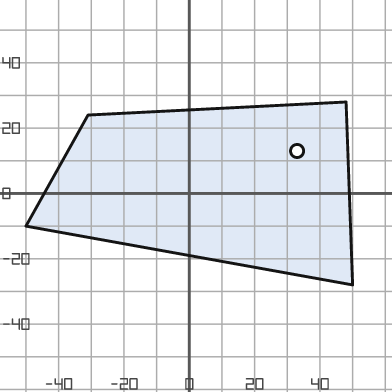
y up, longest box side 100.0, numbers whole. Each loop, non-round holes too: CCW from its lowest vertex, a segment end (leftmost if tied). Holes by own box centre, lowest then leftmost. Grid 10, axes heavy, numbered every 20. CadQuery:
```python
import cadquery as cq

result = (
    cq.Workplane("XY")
    .moveTo(50.0, -28.0)
    .lineTo(48.0, 28.0)
    .lineTo(-31.0, 24.0)
    .lineTo(-50.0, -10.0)
    .close()
    .moveTo(33.0, 13.0)
    .circle(2.0)
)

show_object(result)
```